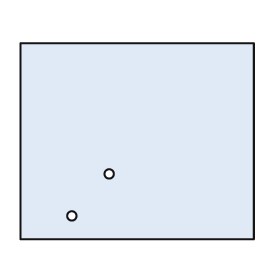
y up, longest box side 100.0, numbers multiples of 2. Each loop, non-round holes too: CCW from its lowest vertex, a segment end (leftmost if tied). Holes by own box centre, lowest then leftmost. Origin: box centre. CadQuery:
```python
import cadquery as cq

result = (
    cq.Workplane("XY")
    .moveTo(-50.0, -42.0)
    .lineTo(50.0, -42.0)
    .lineTo(50.0, 42.0)
    .lineTo(-50.0, 42.0)
    .close()
    .moveTo(-28.0, -32.0)
    .circle(2.0)
    .moveTo(-12.0, -14.0)
    .circle(2.0)
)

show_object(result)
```